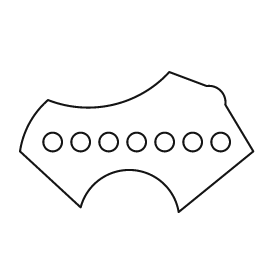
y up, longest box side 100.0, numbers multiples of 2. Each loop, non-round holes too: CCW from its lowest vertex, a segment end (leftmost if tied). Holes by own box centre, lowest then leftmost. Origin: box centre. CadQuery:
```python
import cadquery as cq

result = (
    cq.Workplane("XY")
    .moveTo(18.0, -30.0)
    .lineTo(50.0, -4.0)
    .lineTo(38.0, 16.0)
    .threePointArc((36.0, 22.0), (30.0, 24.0))
    .lineTo(14.0, 30.0)
    .threePointArc((-10.0, 16.0), (-38.0, 18.0))
    .threePointArc((-46.0, 8.0), (-50.0, -4.0))
    .lineTo(-24.0, -28.0)
    .threePointArc((-2.0, -12.0), (18.0, -30.0))
    .close()
    .moveTo(-36.0, 0.0)
    .circle(4.0)
    .moveTo(-24.0, 0.0)
    .circle(4.0)
    .moveTo(-12.0, 0.0)
    .circle(4.0)
    .moveTo(0.0, 0.0)
    .circle(4.0)
    .moveTo(12.0, 0.0)
    .circle(4.0)
    .moveTo(24.0, 0.0)
    .circle(4.0)
    .moveTo(36.0, 0.0)
    .circle(4.0)
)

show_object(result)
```